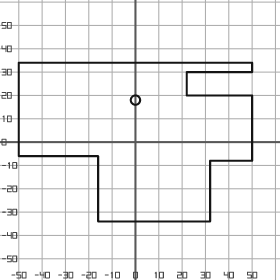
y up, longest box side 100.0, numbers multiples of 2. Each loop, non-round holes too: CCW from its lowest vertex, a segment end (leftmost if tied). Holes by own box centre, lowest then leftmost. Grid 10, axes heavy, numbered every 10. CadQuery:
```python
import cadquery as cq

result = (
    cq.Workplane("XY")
    .moveTo(-16.0, -34.0)
    .lineTo(32.0, -34.0)
    .lineTo(32.0, -8.0)
    .lineTo(50.0, -8.0)
    .lineTo(50.0, 20.0)
    .lineTo(22.0, 20.0)
    .lineTo(22.0, 30.0)
    .lineTo(50.0, 30.0)
    .lineTo(50.0, 34.0)
    .lineTo(-50.0, 34.0)
    .lineTo(-50.0, -6.0)
    .lineTo(-16.0, -6.0)
    .close()
    .moveTo(0.0, 18.0)
    .circle(2.0)
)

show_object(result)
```